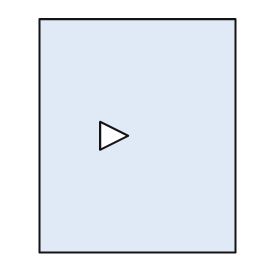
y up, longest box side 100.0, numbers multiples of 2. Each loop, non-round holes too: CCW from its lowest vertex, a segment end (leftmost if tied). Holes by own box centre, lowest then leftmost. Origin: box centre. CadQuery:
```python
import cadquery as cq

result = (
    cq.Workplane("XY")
    .moveTo(-42.0, -50.0)
    .lineTo(42.0, -50.0)
    .lineTo(42.0, 50.0)
    .lineTo(-42.0, 50.0)
    .close()
    .moveTo(-16.0, -6.0)
    .lineTo(-4.0, 0.0)
    .lineTo(-16.0, 6.0)
    .close()
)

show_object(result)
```